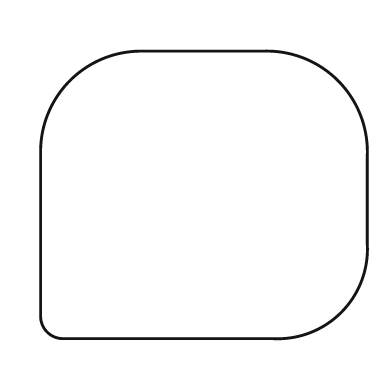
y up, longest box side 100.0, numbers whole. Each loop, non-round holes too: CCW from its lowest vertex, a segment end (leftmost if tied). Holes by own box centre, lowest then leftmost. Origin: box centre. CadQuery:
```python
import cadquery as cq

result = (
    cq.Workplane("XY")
    .moveTo(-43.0, -44.0)
    .lineTo(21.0, -44.0)
    .threePointArc((42.0, -36.0), (50.0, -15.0))
    .lineTo(50.0, 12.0)
    .threePointArc((41.0, 35.0), (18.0, 44.0))
    .lineTo(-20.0, 44.0)
    .threePointArc((-41.0, 35.0), (-50.0, 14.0))
    .lineTo(-50.0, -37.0)
    .threePointArc((-48.0, -42.0), (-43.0, -44.0))
    .close()
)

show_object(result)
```